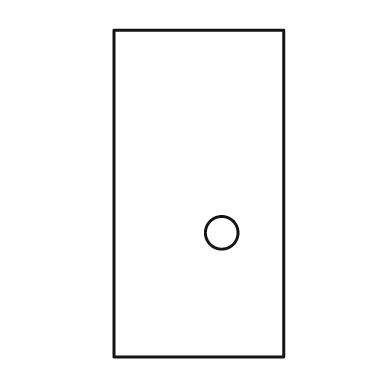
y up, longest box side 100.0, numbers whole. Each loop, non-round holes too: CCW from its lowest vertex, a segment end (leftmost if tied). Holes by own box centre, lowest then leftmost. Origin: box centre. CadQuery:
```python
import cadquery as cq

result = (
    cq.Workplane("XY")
    .moveTo(-26.0, -50.0)
    .lineTo(26.0, -50.0)
    .lineTo(26.0, 50.0)
    .lineTo(-26.0, 50.0)
    .close()
    .moveTo(7.0, -12.0)
    .circle(5.0)
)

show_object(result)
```